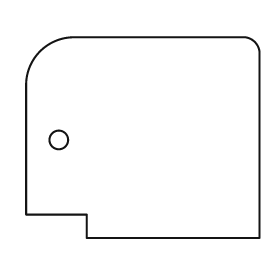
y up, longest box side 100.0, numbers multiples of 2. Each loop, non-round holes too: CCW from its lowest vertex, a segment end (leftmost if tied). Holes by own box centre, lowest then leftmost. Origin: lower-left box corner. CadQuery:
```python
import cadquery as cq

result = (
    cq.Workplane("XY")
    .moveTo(26.0, 0.0)
    .lineTo(100.0, 0.0)
    .lineTo(100.0, 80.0)
    .threePointArc((98.0, 84.0), (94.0, 86.0))
    .lineTo(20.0, 86.0)
    .threePointArc((6.0, 80.0), (0.0, 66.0))
    .lineTo(0.0, 10.0)
    .lineTo(26.0, 10.0)
    .close()
    .moveTo(14.0, 42.0)
    .circle(4.0)
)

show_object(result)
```